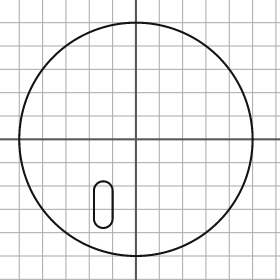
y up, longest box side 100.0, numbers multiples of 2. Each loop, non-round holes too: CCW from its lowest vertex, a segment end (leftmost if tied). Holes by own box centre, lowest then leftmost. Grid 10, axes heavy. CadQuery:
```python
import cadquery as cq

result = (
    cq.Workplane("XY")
    .moveTo(0.0, 0.0)
    .circle(50.0)
    .moveTo(-18.0, -34.0)
    .threePointArc((-14.0, -38.0), (-10.0, -34.0))
    .lineTo(-10.0, -22.0)
    .threePointArc((-14.0, -18.0), (-18.0, -22.0))
    .close()
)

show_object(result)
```